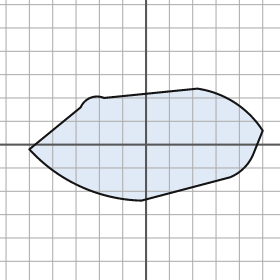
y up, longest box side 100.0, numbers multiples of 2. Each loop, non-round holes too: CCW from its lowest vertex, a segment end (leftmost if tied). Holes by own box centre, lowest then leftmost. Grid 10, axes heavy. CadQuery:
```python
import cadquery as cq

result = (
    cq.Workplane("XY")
    .moveTo(-2.0, -24.0)
    .lineTo(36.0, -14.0)
    .threePointArc((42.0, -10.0), (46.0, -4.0))
    .lineTo(50.0, 6.0)
    .threePointArc((38.0, 18.0), (22.0, 24.0))
    .lineTo(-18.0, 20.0)
    .threePointArc((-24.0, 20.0), (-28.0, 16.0))
    .lineTo(-50.0, -2.0)
    .threePointArc((-28.0, -18.0), (-2.0, -24.0))
    .close()
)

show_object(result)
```